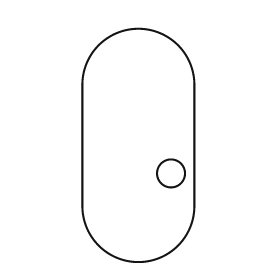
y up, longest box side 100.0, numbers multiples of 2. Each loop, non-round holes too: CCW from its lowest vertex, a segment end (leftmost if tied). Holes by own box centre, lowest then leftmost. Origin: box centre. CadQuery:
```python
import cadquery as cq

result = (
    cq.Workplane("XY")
    .moveTo(-24.0, -26.0)
    .threePointArc((0.0, -50.0), (24.0, -26.0))
    .lineTo(24.0, 26.0)
    .threePointArc((0.0, 50.0), (-24.0, 26.0))
    .close()
    .moveTo(14.0, -12.0)
    .circle(6.0)
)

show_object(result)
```